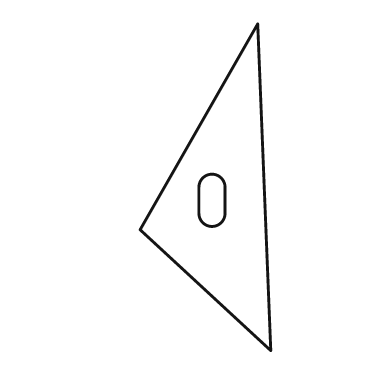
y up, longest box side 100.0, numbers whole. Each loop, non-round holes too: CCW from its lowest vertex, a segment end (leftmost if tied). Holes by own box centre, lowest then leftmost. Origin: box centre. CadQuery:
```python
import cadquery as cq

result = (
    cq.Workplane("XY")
    .moveTo(20.0, -50.0)
    .lineTo(16.0, 50.0)
    .lineTo(-20.0, -13.0)
    .close()
    .moveTo(-2.0, -8.0)
    .threePointArc((2.0, -12.0), (6.0, -8.0))
    .lineTo(6.0, 0.0)
    .threePointArc((2.0, 4.0), (-2.0, 0.0))
    .close()
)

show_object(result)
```